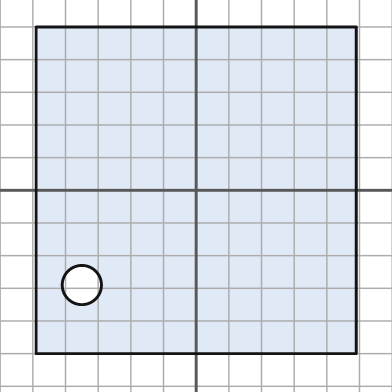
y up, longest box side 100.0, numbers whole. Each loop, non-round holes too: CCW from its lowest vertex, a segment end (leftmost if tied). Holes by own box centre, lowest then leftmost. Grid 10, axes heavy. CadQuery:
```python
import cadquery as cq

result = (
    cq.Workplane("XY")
    .moveTo(-49.0, -50.0)
    .lineTo(49.0, -50.0)
    .lineTo(49.0, 50.0)
    .lineTo(-49.0, 50.0)
    .close()
    .moveTo(-35.0, -29.0)
    .circle(6.0)
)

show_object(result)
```